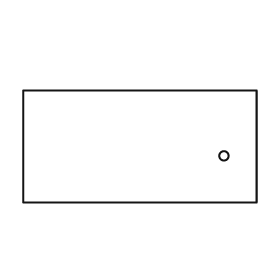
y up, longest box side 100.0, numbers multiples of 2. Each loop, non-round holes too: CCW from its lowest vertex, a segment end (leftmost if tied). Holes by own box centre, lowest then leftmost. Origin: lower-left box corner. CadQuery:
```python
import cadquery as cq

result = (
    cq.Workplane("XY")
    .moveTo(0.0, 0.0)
    .lineTo(100.0, 0.0)
    .lineTo(100.0, 48.0)
    .lineTo(0.0, 48.0)
    .close()
    .moveTo(86.0, 20.0)
    .circle(2.0)
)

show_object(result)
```